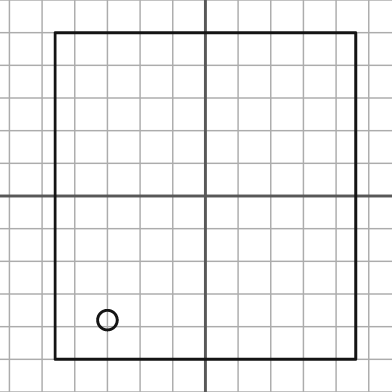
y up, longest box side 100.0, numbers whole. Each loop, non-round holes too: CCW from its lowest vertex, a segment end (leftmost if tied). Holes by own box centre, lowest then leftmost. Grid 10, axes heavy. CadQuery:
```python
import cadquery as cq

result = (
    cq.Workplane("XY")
    .moveTo(-46.0, -50.0)
    .lineTo(46.0, -50.0)
    .lineTo(46.0, 50.0)
    .lineTo(-46.0, 50.0)
    .close()
    .moveTo(-30.0, -38.0)
    .circle(3.0)
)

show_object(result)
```